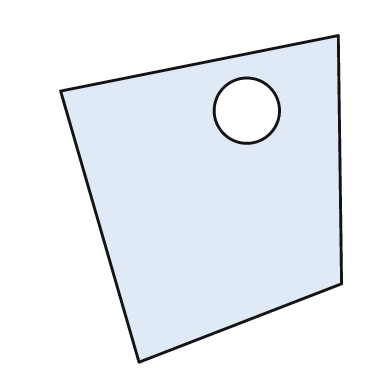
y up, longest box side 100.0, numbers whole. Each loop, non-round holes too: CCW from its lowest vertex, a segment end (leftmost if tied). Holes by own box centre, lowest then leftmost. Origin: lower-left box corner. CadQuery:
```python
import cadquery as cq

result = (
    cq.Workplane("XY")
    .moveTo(24.0, 0.0)
    .lineTo(86.0, 24.0)
    .lineTo(85.0, 100.0)
    .lineTo(0.0, 83.0)
    .close()
    .moveTo(57.0, 77.0)
    .circle(10.0)
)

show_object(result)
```